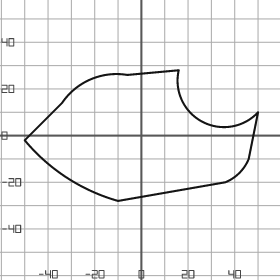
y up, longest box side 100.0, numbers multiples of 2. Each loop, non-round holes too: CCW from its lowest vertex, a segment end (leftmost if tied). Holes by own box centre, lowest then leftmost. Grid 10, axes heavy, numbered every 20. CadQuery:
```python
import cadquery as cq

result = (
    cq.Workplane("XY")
    .moveTo(-10.0, -28.0)
    .lineTo(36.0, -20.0)
    .threePointArc((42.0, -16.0), (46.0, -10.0))
    .lineTo(50.0, 10.0)
    .threePointArc((26.0, 6.0), (16.0, 28.0))
    .lineTo(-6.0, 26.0)
    .threePointArc((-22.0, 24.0), (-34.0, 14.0))
    .lineTo(-50.0, -2.0)
    .threePointArc((-32.0, -18.0), (-10.0, -28.0))
    .close()
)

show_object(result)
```